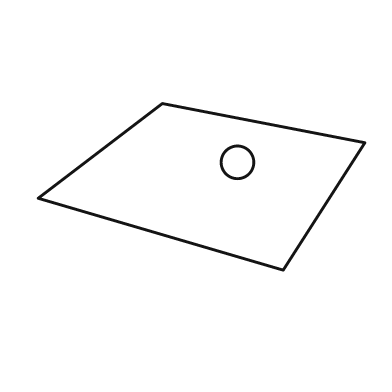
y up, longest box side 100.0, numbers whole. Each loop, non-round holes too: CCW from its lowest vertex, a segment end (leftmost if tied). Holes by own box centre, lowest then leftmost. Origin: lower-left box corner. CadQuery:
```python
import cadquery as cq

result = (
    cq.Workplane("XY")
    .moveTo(75.0, 0.0)
    .lineTo(100.0, 39.0)
    .lineTo(38.0, 51.0)
    .lineTo(0.0, 22.0)
    .close()
    .moveTo(61.0, 33.0)
    .circle(5.0)
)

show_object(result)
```